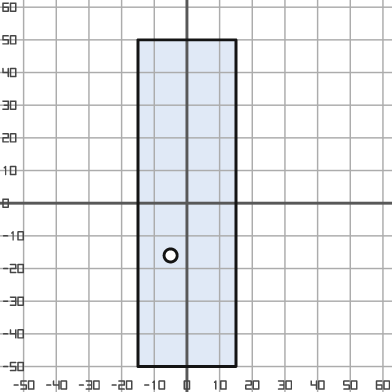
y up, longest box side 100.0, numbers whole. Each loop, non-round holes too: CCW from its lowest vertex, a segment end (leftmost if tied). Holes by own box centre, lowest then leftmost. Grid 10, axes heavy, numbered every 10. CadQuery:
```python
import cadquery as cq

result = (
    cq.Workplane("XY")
    .moveTo(-15.0, -50.0)
    .lineTo(15.0, -50.0)
    .lineTo(15.0, 50.0)
    .lineTo(-15.0, 50.0)
    .close()
    .moveTo(-5.0, -16.0)
    .circle(2.0)
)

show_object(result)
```